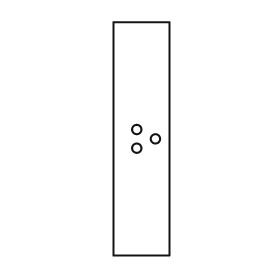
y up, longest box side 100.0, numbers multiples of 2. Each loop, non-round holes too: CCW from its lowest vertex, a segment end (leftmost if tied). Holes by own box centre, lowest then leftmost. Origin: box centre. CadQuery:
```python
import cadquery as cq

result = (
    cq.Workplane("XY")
    .moveTo(-12.0, -50.0)
    .lineTo(12.0, -50.0)
    .lineTo(12.0, 50.0)
    .lineTo(-12.0, 50.0)
    .close()
    .moveTo(-2.0, -4.0)
    .circle(2.0)
    .moveTo(6.0, 0.0)
    .circle(2.0)
    .moveTo(-2.0, 4.0)
    .circle(2.0)
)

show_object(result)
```